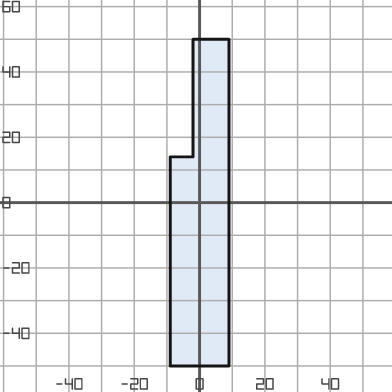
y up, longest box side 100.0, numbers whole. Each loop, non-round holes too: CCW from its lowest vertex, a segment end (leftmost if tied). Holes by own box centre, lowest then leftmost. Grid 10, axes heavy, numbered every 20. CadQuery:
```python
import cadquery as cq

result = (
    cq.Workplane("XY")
    .moveTo(-9.0, -50.0)
    .lineTo(9.0, -50.0)
    .lineTo(9.0, 50.0)
    .lineTo(-2.0, 50.0)
    .lineTo(-2.0, 14.0)
    .lineTo(-9.0, 14.0)
    .close()
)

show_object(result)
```